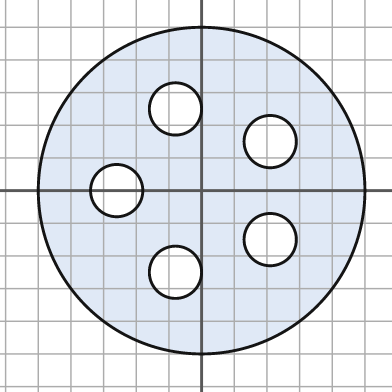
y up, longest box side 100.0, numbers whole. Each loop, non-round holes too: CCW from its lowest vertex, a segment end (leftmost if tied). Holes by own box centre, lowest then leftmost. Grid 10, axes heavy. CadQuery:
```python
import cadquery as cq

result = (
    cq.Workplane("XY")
    .moveTo(0.0, 0.0)
    .circle(50.0)
    .moveTo(-8.0, -25.0)
    .circle(8.0)
    .moveTo(21.0, -15.0)
    .circle(8.0)
    .moveTo(-26.0, 0.0)
    .circle(8.0)
    .moveTo(21.0, 15.0)
    .circle(8.0)
    .moveTo(-8.0, 25.0)
    .circle(8.0)
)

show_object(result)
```